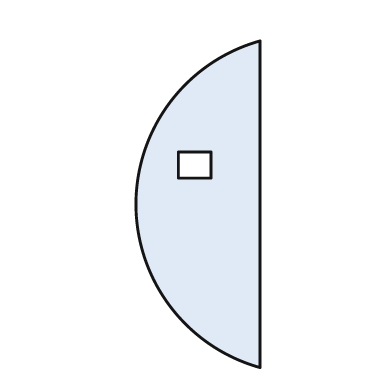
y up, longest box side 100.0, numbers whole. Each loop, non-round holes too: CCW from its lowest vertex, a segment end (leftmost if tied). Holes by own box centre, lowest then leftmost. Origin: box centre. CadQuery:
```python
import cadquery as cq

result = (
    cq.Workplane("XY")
    .moveTo(19.0, -50.0)
    .lineTo(19.0, 50.0)
    .threePointArc((-19.0, 0.0), (19.0, -50.0))
    .close()
    .moveTo(-6.0, 8.0)
    .lineTo(4.0, 8.0)
    .lineTo(4.0, 16.0)
    .lineTo(-6.0, 16.0)
    .close()
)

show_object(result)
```